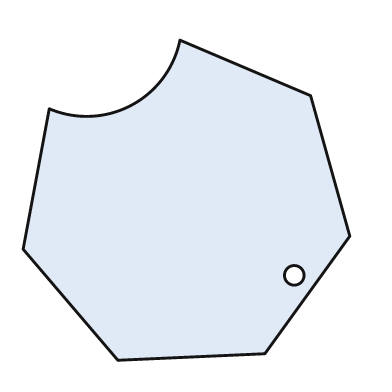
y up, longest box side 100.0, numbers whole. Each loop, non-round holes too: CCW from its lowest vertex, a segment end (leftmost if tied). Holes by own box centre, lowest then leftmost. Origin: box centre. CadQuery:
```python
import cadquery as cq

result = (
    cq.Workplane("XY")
    .moveTo(-21.0, -49.0)
    .lineTo(24.0, -47.0)
    .lineTo(50.0, -11.0)
    .lineTo(38.0, 32.0)
    .lineTo(-2.0, 49.0)
    .threePointArc((-17.0, 29.0), (-42.0, 28.0))
    .lineTo(-50.0, -15.0)
    .close()
    .moveTo(33.0, -23.0)
    .circle(3.0)
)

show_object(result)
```